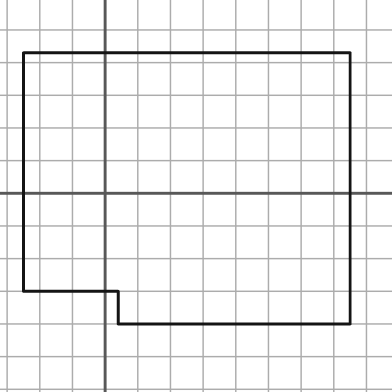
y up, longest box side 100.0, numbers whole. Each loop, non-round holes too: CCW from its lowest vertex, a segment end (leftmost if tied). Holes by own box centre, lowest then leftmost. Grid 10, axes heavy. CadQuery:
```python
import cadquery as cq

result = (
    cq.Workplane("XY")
    .moveTo(4.0, -40.0)
    .lineTo(75.0, -40.0)
    .lineTo(75.0, 43.0)
    .lineTo(-25.0, 43.0)
    .lineTo(-25.0, -30.0)
    .lineTo(4.0, -30.0)
    .close()
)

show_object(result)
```